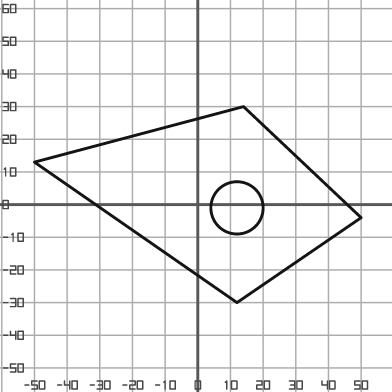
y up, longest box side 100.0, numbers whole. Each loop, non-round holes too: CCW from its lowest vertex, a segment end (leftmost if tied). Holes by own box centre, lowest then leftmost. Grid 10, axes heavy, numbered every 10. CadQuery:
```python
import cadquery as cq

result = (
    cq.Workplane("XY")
    .moveTo(12.0, -30.0)
    .lineTo(50.0, -4.0)
    .lineTo(14.0, 30.0)
    .lineTo(-50.0, 13.0)
    .close()
    .moveTo(12.0, -1.0)
    .circle(8.0)
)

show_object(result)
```